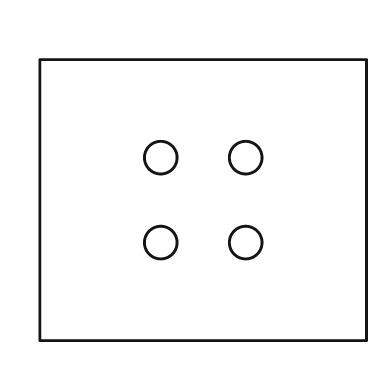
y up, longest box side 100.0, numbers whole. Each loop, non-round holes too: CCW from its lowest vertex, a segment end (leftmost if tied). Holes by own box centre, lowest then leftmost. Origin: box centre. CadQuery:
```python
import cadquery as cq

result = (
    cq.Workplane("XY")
    .moveTo(-50.0, -43.0)
    .lineTo(50.0, -43.0)
    .lineTo(50.0, 43.0)
    .lineTo(-50.0, 43.0)
    .close()
    .moveTo(-13.0, -13.0)
    .circle(5.0)
    .moveTo(13.0, -13.0)
    .circle(5.0)
    .moveTo(-13.0, 13.0)
    .circle(5.0)
    .moveTo(13.0, 13.0)
    .circle(5.0)
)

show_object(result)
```